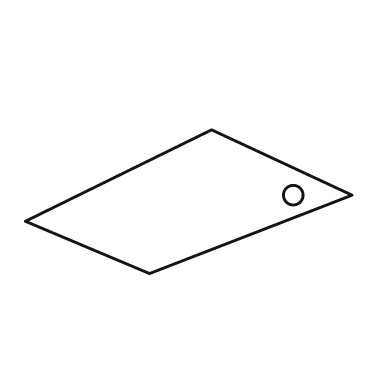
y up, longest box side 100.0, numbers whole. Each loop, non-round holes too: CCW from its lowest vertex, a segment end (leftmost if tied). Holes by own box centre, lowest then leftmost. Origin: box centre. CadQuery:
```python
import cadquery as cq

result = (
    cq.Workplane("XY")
    .moveTo(-12.0, -22.0)
    .lineTo(50.0, 2.0)
    .lineTo(7.0, 22.0)
    .lineTo(-50.0, -6.0)
    .close()
    .moveTo(32.0, 2.0)
    .circle(3.0)
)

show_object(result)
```